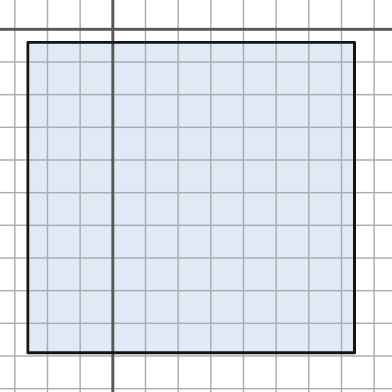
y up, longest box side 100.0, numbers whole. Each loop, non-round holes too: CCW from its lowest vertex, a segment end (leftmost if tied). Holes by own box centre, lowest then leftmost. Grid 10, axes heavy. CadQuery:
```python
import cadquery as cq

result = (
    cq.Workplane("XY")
    .moveTo(-26.0, -99.0)
    .lineTo(74.0, -99.0)
    .lineTo(74.0, -4.0)
    .lineTo(-26.0, -4.0)
    .close()
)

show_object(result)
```